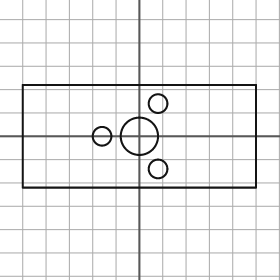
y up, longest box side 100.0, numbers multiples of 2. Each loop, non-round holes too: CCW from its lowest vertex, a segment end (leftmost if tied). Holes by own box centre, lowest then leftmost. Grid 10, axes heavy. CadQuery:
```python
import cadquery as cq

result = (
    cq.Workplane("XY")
    .moveTo(-50.0, -22.0)
    .lineTo(50.0, -22.0)
    .lineTo(50.0, 22.0)
    .lineTo(-50.0, 22.0)
    .close()
    .moveTo(8.0, -14.0)
    .circle(4.0)
    .moveTo(-16.0, 0.0)
    .circle(4.0)
    .moveTo(0.0, 0.0)
    .circle(8.0)
    .moveTo(8.0, 14.0)
    .circle(4.0)
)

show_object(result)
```